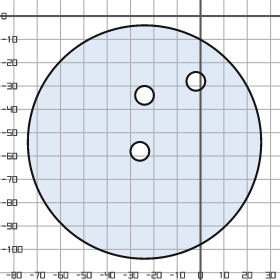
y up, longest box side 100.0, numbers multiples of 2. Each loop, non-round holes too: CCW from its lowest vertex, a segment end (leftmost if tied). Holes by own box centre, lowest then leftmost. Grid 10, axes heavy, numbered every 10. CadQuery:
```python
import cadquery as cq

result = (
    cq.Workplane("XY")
    .moveTo(-24.0, -54.0)
    .circle(50.0)
    .moveTo(-26.0, -58.0)
    .circle(4.0)
    .moveTo(-24.0, -34.0)
    .circle(4.0)
    .moveTo(-2.0, -28.0)
    .circle(4.0)
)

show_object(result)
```